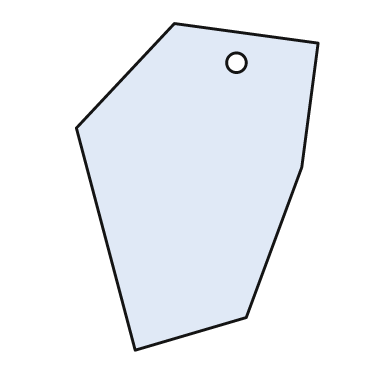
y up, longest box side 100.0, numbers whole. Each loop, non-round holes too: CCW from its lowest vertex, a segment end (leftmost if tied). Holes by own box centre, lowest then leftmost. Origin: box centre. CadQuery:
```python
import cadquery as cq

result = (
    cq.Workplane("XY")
    .moveTo(-19.0, -50.0)
    .lineTo(15.0, -40.0)
    .lineTo(32.0, 6.0)
    .lineTo(37.0, 44.0)
    .lineTo(-7.0, 50.0)
    .lineTo(-37.0, 18.0)
    .close()
    .moveTo(12.0, 38.0)
    .circle(3.0)
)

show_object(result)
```